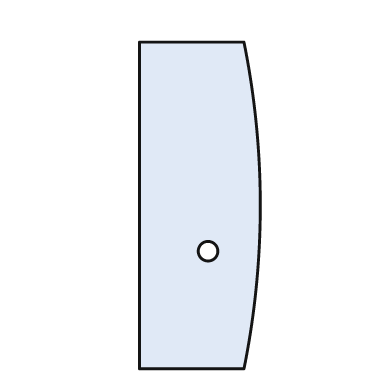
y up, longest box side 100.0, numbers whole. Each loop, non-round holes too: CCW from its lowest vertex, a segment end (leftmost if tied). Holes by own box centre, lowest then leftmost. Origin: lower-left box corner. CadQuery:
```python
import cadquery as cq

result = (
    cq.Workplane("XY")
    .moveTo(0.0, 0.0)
    .lineTo(32.0, 0.0)
    .threePointArc((37.0, 50.0), (32.0, 100.0))
    .lineTo(0.0, 100.0)
    .close()
    .moveTo(21.0, 36.0)
    .circle(3.0)
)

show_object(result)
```